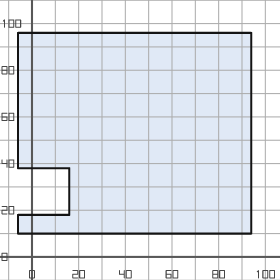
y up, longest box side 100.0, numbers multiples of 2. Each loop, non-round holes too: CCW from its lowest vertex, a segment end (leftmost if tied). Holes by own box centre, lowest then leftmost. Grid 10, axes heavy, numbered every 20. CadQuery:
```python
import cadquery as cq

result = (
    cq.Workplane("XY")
    .moveTo(-6.0, 10.0)
    .lineTo(94.0, 10.0)
    .lineTo(94.0, 96.0)
    .lineTo(-6.0, 96.0)
    .lineTo(-6.0, 38.0)
    .lineTo(16.0, 38.0)
    .lineTo(16.0, 18.0)
    .lineTo(-6.0, 18.0)
    .close()
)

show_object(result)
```